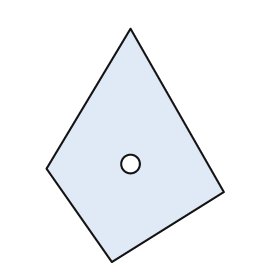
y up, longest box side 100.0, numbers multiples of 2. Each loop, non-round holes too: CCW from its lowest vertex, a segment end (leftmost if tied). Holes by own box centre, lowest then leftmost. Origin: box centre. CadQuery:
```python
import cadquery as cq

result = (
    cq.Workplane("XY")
    .moveTo(-10.0, -50.0)
    .lineTo(38.0, -20.0)
    .lineTo(-2.0, 50.0)
    .lineTo(-38.0, -10.0)
    .close()
    .moveTo(-2.0, -8.0)
    .circle(4.0)
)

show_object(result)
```